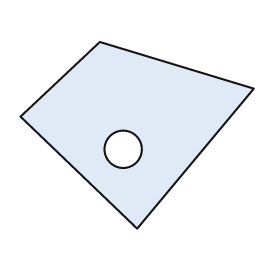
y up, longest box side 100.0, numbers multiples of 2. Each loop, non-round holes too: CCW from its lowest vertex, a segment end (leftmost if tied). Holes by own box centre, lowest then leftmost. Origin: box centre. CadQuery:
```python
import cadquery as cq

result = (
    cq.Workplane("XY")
    .moveTo(0.0, -40.0)
    .lineTo(50.0, 20.0)
    .lineTo(-16.0, 40.0)
    .lineTo(-50.0, 8.0)
    .close()
    .moveTo(-6.0, -6.0)
    .circle(8.0)
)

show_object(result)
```